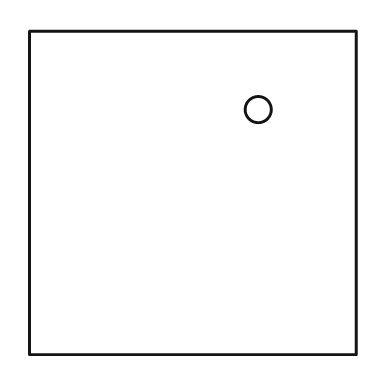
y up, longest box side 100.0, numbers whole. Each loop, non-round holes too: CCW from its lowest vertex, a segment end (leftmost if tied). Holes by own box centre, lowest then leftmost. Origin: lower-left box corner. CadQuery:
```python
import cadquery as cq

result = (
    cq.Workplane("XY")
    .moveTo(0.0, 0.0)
    .lineTo(100.0, 0.0)
    .lineTo(100.0, 99.0)
    .lineTo(0.0, 99.0)
    .close()
    .moveTo(70.0, 75.0)
    .circle(4.0)
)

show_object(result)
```